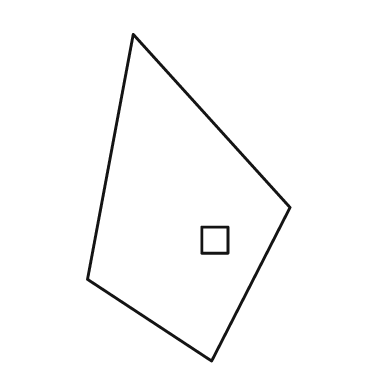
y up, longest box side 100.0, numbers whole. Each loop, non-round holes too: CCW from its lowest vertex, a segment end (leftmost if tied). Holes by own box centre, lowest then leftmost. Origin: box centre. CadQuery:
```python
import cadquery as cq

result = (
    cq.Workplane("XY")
    .moveTo(7.0, -50.0)
    .lineTo(31.0, -3.0)
    .lineTo(-17.0, 50.0)
    .lineTo(-31.0, -25.0)
    .close()
    .moveTo(4.0, -17.0)
    .lineTo(12.0, -17.0)
    .lineTo(12.0, -9.0)
    .lineTo(4.0, -9.0)
    .close()
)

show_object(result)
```